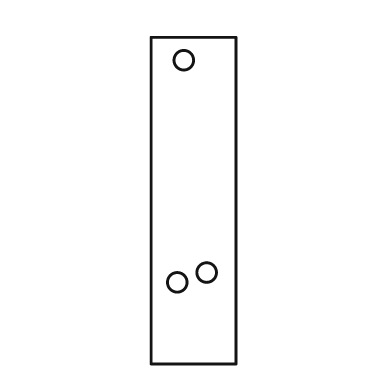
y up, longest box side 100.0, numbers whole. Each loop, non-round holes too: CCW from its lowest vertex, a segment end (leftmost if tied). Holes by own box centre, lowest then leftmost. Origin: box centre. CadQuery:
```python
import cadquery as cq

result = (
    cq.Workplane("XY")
    .moveTo(-13.0, -50.0)
    .lineTo(13.0, -50.0)
    .lineTo(13.0, 50.0)
    .lineTo(-13.0, 50.0)
    .close()
    .moveTo(-5.0, -25.0)
    .circle(3.0)
    .moveTo(4.0, -22.0)
    .circle(3.0)
    .moveTo(-3.0, 43.0)
    .circle(3.0)
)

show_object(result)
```